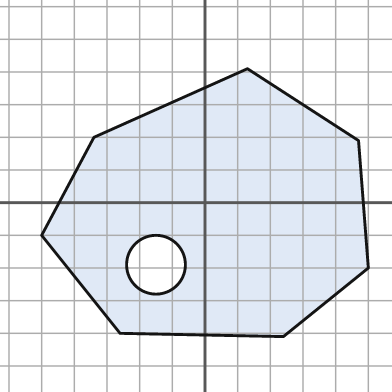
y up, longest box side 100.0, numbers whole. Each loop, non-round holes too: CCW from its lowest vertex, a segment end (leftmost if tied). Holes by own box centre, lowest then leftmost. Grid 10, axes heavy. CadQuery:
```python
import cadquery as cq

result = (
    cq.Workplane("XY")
    .moveTo(24.0, -41.0)
    .lineTo(50.0, -20.0)
    .lineTo(47.0, 19.0)
    .lineTo(13.0, 41.0)
    .lineTo(-34.0, 20.0)
    .lineTo(-50.0, -10.0)
    .lineTo(-26.0, -40.0)
    .close()
    .moveTo(-15.0, -19.0)
    .circle(9.0)
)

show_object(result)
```